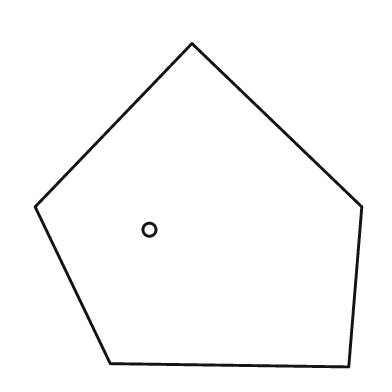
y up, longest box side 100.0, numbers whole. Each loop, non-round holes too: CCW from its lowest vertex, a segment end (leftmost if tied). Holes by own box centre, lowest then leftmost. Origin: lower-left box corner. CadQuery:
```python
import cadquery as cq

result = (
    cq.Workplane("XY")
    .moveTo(96.0, 0.0)
    .lineTo(100.0, 49.0)
    .lineTo(48.0, 99.0)
    .lineTo(0.0, 49.0)
    .lineTo(23.0, 1.0)
    .close()
    .moveTo(35.0, 42.0)
    .circle(2.0)
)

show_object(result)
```